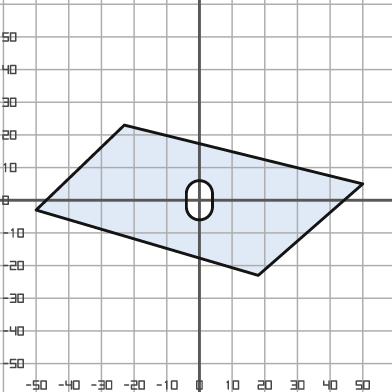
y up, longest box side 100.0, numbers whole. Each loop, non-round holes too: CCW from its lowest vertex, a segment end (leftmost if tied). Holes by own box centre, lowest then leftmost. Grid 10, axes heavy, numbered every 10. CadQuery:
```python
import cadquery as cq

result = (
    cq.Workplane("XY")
    .moveTo(18.0, -23.0)
    .lineTo(50.0, 5.0)
    .lineTo(-23.0, 23.0)
    .lineTo(-50.0, -3.0)
    .close()
    .moveTo(-4.0, -2.0)
    .threePointArc((0.0, -6.0), (4.0, -2.0))
    .lineTo(4.0, 2.0)
    .threePointArc((0.0, 6.0), (-4.0, 2.0))
    .close()
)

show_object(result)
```